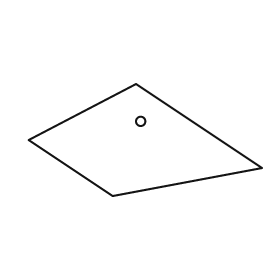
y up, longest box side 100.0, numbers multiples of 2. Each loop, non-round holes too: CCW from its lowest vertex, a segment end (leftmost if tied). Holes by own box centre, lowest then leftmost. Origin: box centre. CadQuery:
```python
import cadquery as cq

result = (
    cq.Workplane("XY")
    .moveTo(-14.0, -24.0)
    .lineTo(50.0, -12.0)
    .lineTo(-4.0, 24.0)
    .lineTo(-50.0, 0.0)
    .close()
    .moveTo(-2.0, 8.0)
    .circle(2.0)
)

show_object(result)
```